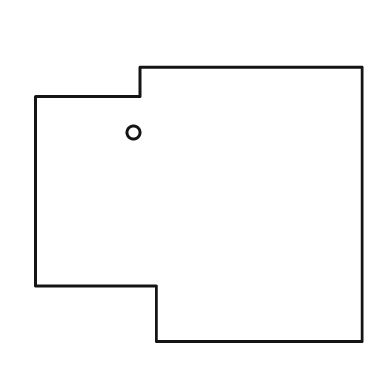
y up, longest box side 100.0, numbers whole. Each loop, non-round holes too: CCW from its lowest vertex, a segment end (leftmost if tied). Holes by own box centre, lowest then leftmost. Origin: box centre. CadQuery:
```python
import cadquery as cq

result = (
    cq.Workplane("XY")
    .moveTo(-13.0, -42.0)
    .lineTo(50.0, -42.0)
    .lineTo(50.0, 42.0)
    .lineTo(-18.0, 42.0)
    .lineTo(-18.0, 33.0)
    .lineTo(-50.0, 33.0)
    .lineTo(-50.0, -25.0)
    .lineTo(-13.0, -25.0)
    .close()
    .moveTo(-20.0, 22.0)
    .circle(2.0)
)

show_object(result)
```